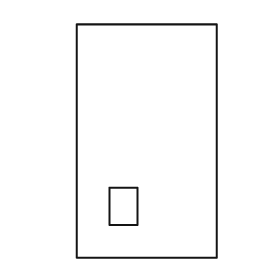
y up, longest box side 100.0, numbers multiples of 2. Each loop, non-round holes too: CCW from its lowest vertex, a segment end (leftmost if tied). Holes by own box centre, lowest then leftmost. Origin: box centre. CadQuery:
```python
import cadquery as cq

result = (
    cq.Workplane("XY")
    .moveTo(-30.0, -50.0)
    .lineTo(30.0, -50.0)
    .lineTo(30.0, 50.0)
    .lineTo(-30.0, 50.0)
    .close()
    .moveTo(-16.0, -36.0)
    .lineTo(-4.0, -36.0)
    .lineTo(-4.0, -20.0)
    .lineTo(-16.0, -20.0)
    .close()
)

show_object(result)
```